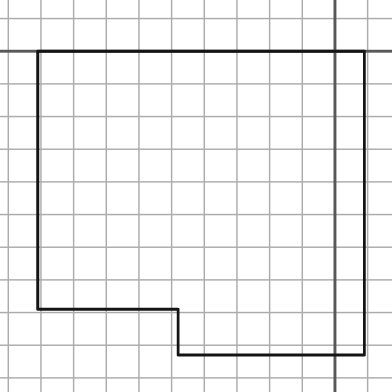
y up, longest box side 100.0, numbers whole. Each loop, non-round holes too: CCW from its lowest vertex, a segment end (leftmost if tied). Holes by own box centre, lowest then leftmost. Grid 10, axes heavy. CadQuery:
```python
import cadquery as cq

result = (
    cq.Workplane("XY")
    .moveTo(-48.0, -93.0)
    .lineTo(9.0, -93.0)
    .lineTo(9.0, 0.0)
    .lineTo(-91.0, 0.0)
    .lineTo(-91.0, -79.0)
    .lineTo(-48.0, -79.0)
    .close()
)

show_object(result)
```